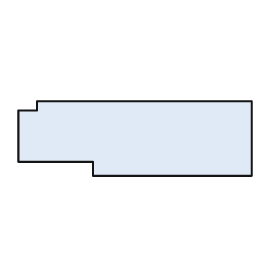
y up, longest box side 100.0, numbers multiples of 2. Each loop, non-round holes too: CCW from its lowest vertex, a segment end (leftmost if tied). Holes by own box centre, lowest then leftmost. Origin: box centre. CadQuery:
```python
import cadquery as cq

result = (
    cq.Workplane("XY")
    .moveTo(-18.0, -16.0)
    .lineTo(50.0, -16.0)
    .lineTo(50.0, 16.0)
    .lineTo(-42.0, 16.0)
    .lineTo(-42.0, 12.0)
    .lineTo(-50.0, 12.0)
    .lineTo(-50.0, -10.0)
    .lineTo(-18.0, -10.0)
    .close()
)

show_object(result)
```